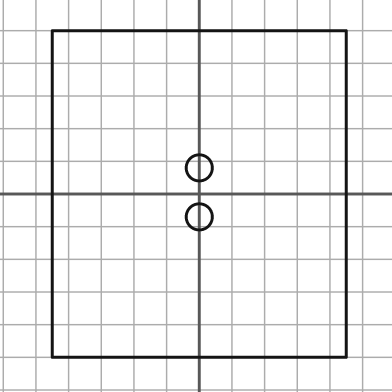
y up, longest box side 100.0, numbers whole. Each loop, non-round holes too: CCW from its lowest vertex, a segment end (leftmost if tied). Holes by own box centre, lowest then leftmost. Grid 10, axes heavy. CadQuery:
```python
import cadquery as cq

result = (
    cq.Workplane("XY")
    .moveTo(-45.0, -50.0)
    .lineTo(45.0, -50.0)
    .lineTo(45.0, 50.0)
    .lineTo(-45.0, 50.0)
    .close()
    .moveTo(0.0, -7.0)
    .circle(4.0)
    .moveTo(0.0, 8.0)
    .circle(4.0)
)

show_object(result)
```